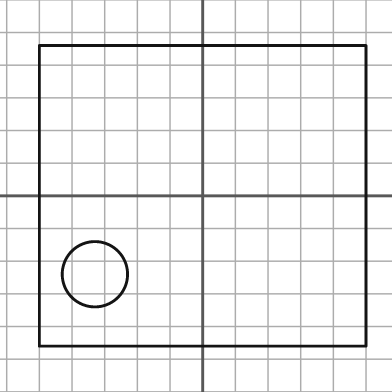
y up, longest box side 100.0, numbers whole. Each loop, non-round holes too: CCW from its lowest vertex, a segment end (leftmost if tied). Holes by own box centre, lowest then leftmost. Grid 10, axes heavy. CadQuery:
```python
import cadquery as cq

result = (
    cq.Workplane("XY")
    .moveTo(-50.0, -46.0)
    .lineTo(50.0, -46.0)
    .lineTo(50.0, 46.0)
    .lineTo(-50.0, 46.0)
    .close()
    .moveTo(-33.0, -24.0)
    .circle(10.0)
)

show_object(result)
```